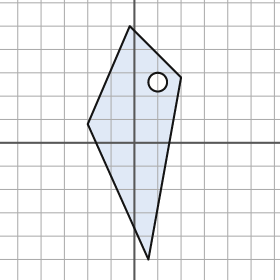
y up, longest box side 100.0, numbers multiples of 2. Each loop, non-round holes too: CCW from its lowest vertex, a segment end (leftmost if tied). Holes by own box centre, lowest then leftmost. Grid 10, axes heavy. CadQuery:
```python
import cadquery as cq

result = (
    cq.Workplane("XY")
    .moveTo(6.0, -50.0)
    .lineTo(20.0, 28.0)
    .lineTo(-2.0, 50.0)
    .lineTo(-20.0, 8.0)
    .close()
    .moveTo(10.0, 26.0)
    .circle(4.0)
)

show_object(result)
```